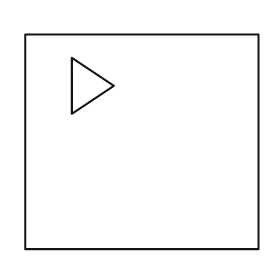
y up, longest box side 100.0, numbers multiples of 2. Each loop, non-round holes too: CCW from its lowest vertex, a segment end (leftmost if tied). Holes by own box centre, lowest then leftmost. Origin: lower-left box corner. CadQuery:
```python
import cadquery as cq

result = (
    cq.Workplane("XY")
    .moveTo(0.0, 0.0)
    .lineTo(100.0, 0.0)
    .lineTo(100.0, 92.0)
    .lineTo(0.0, 92.0)
    .close()
    .moveTo(20.0, 58.0)
    .lineTo(38.0, 70.0)
    .lineTo(20.0, 82.0)
    .close()
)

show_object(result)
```